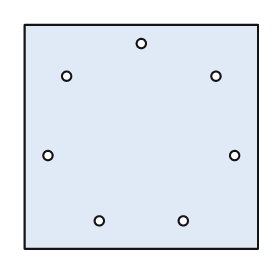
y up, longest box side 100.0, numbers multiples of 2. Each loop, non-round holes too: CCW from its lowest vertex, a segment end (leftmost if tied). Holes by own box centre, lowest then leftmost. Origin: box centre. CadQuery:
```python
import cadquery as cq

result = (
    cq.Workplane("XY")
    .moveTo(-50.0, -48.0)
    .lineTo(50.0, -48.0)
    .lineTo(50.0, 48.0)
    .lineTo(-50.0, 48.0)
    .close()
    .moveTo(-18.0, -36.0)
    .circle(2.0)
    .moveTo(18.0, -36.0)
    .circle(2.0)
    .moveTo(-40.0, -8.0)
    .circle(2.0)
    .moveTo(40.0, -8.0)
    .circle(2.0)
    .moveTo(-32.0, 26.0)
    .circle(2.0)
    .moveTo(32.0, 26.0)
    .circle(2.0)
    .moveTo(0.0, 40.0)
    .circle(2.0)
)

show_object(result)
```